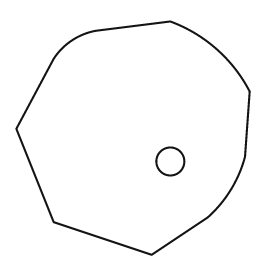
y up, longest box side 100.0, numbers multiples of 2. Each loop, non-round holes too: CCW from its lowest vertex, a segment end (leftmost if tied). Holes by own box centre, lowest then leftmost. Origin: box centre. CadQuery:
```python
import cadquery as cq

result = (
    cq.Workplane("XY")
    .moveTo(8.0, -50.0)
    .lineTo(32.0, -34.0)
    .threePointArc((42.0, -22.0), (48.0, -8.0))
    .lineTo(50.0, 20.0)
    .threePointArc((36.0, 38.0), (16.0, 50.0))
    .lineTo(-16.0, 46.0)
    .threePointArc((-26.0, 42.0), (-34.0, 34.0))
    .lineTo(-50.0, 4.0)
    .lineTo(-34.0, -36.0)
    .close()
    .moveTo(16.0, -10.0)
    .circle(6.0)
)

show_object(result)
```